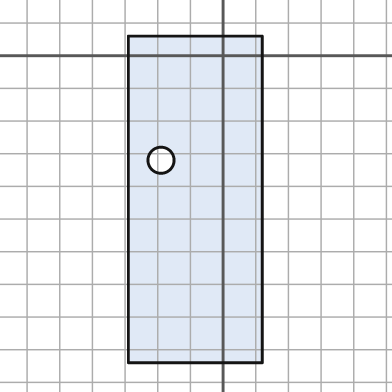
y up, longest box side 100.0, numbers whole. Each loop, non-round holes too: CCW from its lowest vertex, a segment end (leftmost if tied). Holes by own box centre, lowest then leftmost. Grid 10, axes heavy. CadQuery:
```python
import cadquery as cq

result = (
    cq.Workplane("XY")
    .moveTo(-29.0, -94.0)
    .lineTo(12.0, -94.0)
    .lineTo(12.0, 6.0)
    .lineTo(-29.0, 6.0)
    .close()
    .moveTo(-19.0, -32.0)
    .circle(4.0)
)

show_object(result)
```